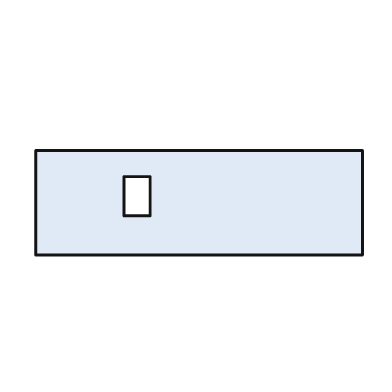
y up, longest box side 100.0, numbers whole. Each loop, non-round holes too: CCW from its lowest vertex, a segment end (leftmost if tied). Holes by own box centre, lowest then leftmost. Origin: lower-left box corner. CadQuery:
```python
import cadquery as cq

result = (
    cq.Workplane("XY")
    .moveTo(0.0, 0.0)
    .lineTo(100.0, 0.0)
    .lineTo(100.0, 32.0)
    .lineTo(0.0, 32.0)
    .close()
    .moveTo(27.0, 12.0)
    .lineTo(35.0, 12.0)
    .lineTo(35.0, 24.0)
    .lineTo(27.0, 24.0)
    .close()
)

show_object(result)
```